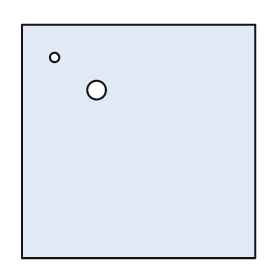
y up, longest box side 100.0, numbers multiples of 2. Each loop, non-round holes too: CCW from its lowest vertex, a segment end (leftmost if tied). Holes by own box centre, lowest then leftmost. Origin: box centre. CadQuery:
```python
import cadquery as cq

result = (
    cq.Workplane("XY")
    .moveTo(-50.0, -50.0)
    .lineTo(50.0, -50.0)
    .lineTo(50.0, 50.0)
    .lineTo(-50.0, 50.0)
    .close()
    .moveTo(-18.0, 22.0)
    .circle(4.0)
    .moveTo(-36.0, 36.0)
    .circle(2.0)
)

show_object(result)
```